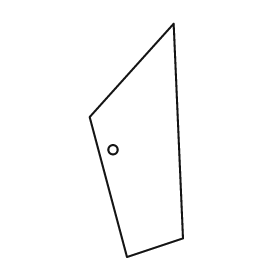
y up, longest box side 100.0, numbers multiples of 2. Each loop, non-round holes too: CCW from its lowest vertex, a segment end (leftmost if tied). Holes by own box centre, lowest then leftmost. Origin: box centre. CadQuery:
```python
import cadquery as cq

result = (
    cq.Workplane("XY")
    .moveTo(-4.0, -50.0)
    .lineTo(20.0, -42.0)
    .lineTo(16.0, 50.0)
    .lineTo(-20.0, 10.0)
    .close()
    .moveTo(-10.0, -4.0)
    .circle(2.0)
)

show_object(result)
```